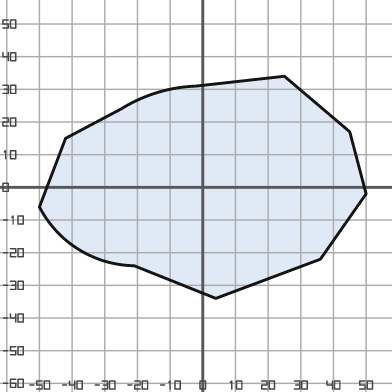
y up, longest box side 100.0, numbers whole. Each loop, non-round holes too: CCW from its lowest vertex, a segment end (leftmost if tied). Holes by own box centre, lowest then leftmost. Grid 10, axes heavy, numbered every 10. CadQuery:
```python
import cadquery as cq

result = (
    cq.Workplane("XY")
    .moveTo(4.0, -34.0)
    .lineTo(36.0, -22.0)
    .lineTo(50.0, -2.0)
    .lineTo(45.0, 17.0)
    .lineTo(25.0, 34.0)
    .lineTo(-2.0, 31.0)
    .threePointArc((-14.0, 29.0), (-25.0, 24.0))
    .lineTo(-42.0, 15.0)
    .lineTo(-50.0, -6.0)
    .threePointArc((-38.0, -19.0), (-21.0, -24.0))
    .close()
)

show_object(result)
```